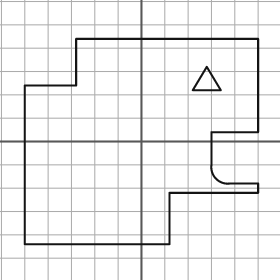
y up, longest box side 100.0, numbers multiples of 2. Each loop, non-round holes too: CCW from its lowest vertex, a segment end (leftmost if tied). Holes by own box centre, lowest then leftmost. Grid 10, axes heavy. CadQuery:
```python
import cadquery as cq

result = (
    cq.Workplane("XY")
    .moveTo(-50.0, -44.0)
    .lineTo(12.0, -44.0)
    .lineTo(12.0, -22.0)
    .lineTo(50.0, -22.0)
    .lineTo(50.0, -18.0)
    .lineTo(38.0, -18.0)
    .threePointArc((32.0, -16.0), (30.0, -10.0))
    .lineTo(30.0, 4.0)
    .lineTo(50.0, 4.0)
    .lineTo(50.0, 44.0)
    .lineTo(-28.0, 44.0)
    .lineTo(-28.0, 24.0)
    .lineTo(-50.0, 24.0)
    .close()
    .moveTo(22.0, 22.0)
    .lineTo(34.0, 22.0)
    .lineTo(28.0, 32.0)
    .close()
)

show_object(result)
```